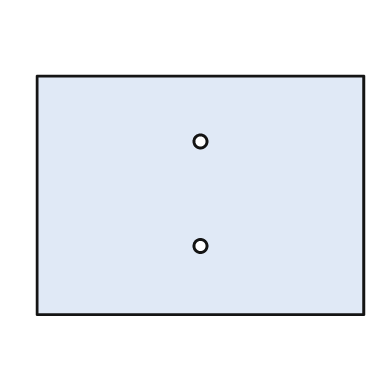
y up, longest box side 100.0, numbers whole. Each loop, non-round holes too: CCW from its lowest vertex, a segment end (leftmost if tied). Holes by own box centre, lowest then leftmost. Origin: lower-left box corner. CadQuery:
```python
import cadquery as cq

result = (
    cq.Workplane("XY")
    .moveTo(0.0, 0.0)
    .lineTo(100.0, 0.0)
    .lineTo(100.0, 73.0)
    .lineTo(0.0, 73.0)
    .close()
    .moveTo(50.0, 21.0)
    .circle(2.0)
    .moveTo(50.0, 53.0)
    .circle(2.0)
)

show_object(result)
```